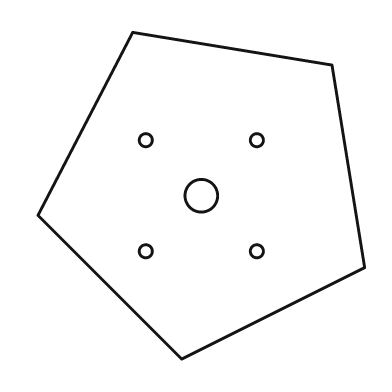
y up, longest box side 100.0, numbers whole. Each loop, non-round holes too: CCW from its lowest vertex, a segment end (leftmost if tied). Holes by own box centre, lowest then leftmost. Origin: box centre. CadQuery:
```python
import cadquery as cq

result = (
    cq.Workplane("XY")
    .moveTo(-6.0, -50.0)
    .lineTo(50.0, -22.0)
    .lineTo(40.0, 40.0)
    .lineTo(-21.0, 50.0)
    .lineTo(-50.0, -6.0)
    .close()
    .moveTo(-17.0, -17.0)
    .circle(2.0)
    .moveTo(17.0, -17.0)
    .circle(2.0)
    .moveTo(0.0, 0.0)
    .circle(5.0)
    .moveTo(-17.0, 17.0)
    .circle(2.0)
    .moveTo(17.0, 17.0)
    .circle(2.0)
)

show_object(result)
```